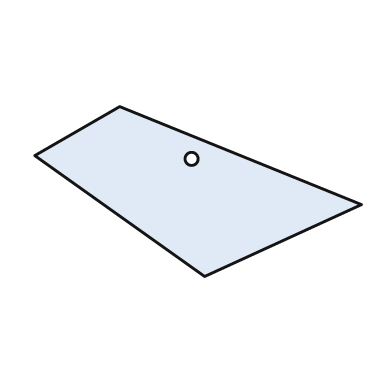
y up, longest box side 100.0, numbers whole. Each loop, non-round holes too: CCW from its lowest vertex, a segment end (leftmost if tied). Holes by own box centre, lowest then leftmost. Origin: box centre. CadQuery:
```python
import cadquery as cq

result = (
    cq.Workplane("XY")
    .moveTo(2.0, -26.0)
    .lineTo(50.0, -4.0)
    .lineTo(-24.0, 26.0)
    .lineTo(-50.0, 11.0)
    .close()
    .moveTo(-2.0, 10.0)
    .circle(2.0)
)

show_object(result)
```